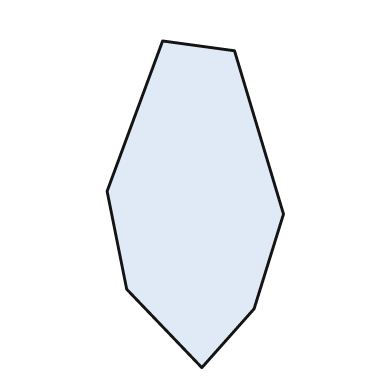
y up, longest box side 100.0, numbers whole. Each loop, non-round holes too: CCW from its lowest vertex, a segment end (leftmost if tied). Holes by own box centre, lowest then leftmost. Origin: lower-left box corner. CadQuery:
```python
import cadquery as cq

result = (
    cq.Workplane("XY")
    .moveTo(29.0, 0.0)
    .lineTo(45.0, 18.0)
    .lineTo(54.0, 47.0)
    .lineTo(39.0, 97.0)
    .lineTo(17.0, 100.0)
    .lineTo(0.0, 54.0)
    .lineTo(6.0, 24.0)
    .close()
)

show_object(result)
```